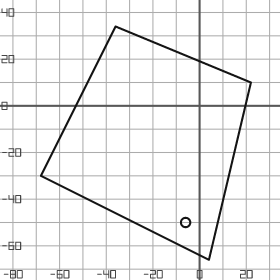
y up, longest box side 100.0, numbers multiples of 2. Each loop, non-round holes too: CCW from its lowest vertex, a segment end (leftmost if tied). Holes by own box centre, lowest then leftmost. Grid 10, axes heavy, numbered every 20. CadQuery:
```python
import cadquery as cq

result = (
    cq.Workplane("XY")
    .moveTo(4.0, -66.0)
    .lineTo(22.0, 10.0)
    .lineTo(-36.0, 34.0)
    .lineTo(-68.0, -30.0)
    .close()
    .moveTo(-6.0, -50.0)
    .circle(2.0)
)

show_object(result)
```